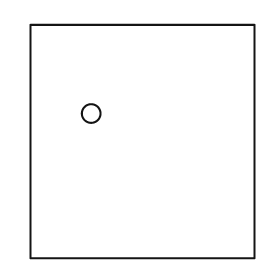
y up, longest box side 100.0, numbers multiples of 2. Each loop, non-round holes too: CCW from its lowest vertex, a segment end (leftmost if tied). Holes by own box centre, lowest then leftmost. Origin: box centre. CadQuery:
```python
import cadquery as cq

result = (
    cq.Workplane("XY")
    .moveTo(-48.0, -50.0)
    .lineTo(48.0, -50.0)
    .lineTo(48.0, 50.0)
    .lineTo(-48.0, 50.0)
    .close()
    .moveTo(-22.0, 12.0)
    .circle(4.0)
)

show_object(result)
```